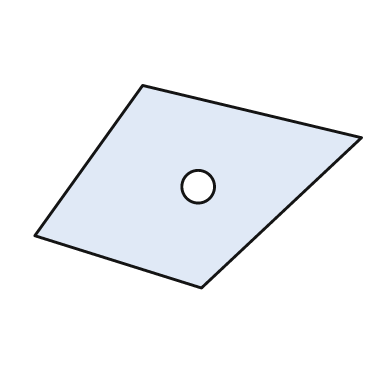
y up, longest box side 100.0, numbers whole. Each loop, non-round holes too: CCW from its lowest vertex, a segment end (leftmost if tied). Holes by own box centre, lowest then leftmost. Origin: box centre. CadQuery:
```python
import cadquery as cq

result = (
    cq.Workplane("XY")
    .moveTo(1.0, -31.0)
    .lineTo(50.0, 15.0)
    .lineTo(-17.0, 31.0)
    .lineTo(-50.0, -15.0)
    .close()
    .moveTo(0.0, 0.0)
    .circle(5.0)
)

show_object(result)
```